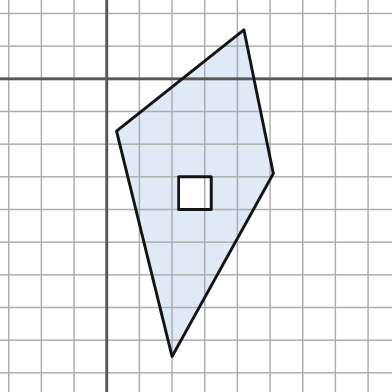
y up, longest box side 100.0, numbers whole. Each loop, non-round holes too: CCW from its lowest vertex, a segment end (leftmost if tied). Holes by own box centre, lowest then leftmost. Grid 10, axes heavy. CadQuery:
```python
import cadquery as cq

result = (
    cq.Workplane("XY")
    .moveTo(20.0, -85.0)
    .lineTo(51.0, -29.0)
    .lineTo(42.0, 15.0)
    .lineTo(3.0, -16.0)
    .close()
    .moveTo(22.0, -40.0)
    .lineTo(32.0, -40.0)
    .lineTo(32.0, -30.0)
    .lineTo(22.0, -30.0)
    .close()
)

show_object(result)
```